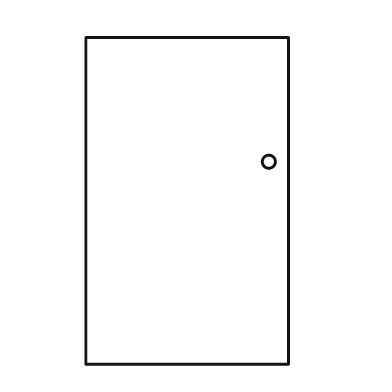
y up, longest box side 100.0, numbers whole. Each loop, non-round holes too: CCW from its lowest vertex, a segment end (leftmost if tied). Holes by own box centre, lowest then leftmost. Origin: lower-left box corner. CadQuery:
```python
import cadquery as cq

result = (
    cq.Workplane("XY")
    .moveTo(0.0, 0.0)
    .lineTo(62.0, 0.0)
    .lineTo(62.0, 100.0)
    .lineTo(0.0, 100.0)
    .close()
    .moveTo(56.0, 62.0)
    .circle(2.0)
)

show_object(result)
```